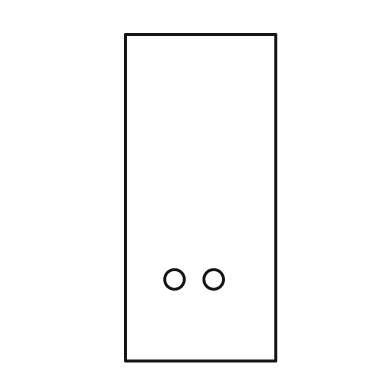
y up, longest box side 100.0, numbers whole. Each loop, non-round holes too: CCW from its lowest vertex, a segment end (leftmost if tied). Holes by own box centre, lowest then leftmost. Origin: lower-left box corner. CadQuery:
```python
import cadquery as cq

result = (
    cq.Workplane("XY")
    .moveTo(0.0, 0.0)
    .lineTo(46.0, 0.0)
    .lineTo(46.0, 100.0)
    .lineTo(0.0, 100.0)
    .close()
    .moveTo(15.0, 25.0)
    .circle(3.0)
    .moveTo(27.0, 25.0)
    .circle(3.0)
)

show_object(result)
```